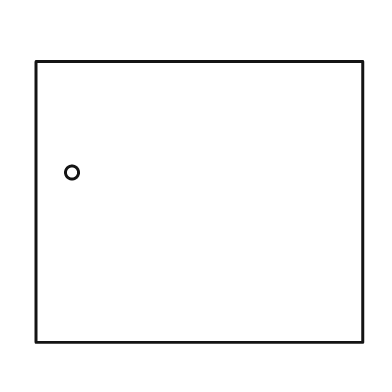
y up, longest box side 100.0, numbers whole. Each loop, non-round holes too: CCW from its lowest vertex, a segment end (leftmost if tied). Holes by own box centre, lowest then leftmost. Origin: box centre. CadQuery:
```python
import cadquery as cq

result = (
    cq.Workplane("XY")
    .moveTo(-50.0, -43.0)
    .lineTo(50.0, -43.0)
    .lineTo(50.0, 43.0)
    .lineTo(-50.0, 43.0)
    .close()
    .moveTo(-39.0, 9.0)
    .circle(2.0)
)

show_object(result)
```